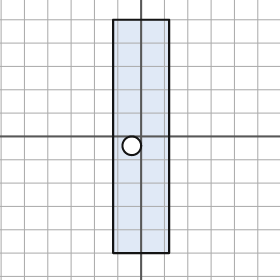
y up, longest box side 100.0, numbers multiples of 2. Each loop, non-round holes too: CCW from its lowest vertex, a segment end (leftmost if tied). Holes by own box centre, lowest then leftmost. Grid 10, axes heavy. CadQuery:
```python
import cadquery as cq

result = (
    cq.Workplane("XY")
    .moveTo(-12.0, -50.0)
    .lineTo(12.0, -50.0)
    .lineTo(12.0, 50.0)
    .lineTo(-12.0, 50.0)
    .close()
    .moveTo(-4.0, -4.0)
    .circle(4.0)
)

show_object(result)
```